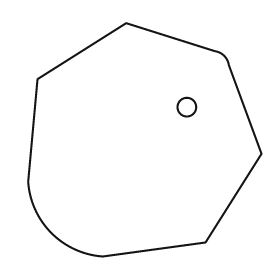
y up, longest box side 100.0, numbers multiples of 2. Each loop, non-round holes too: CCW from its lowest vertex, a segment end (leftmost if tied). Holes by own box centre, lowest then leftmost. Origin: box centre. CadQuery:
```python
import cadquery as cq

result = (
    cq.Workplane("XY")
    .moveTo(-18.0, -50.0)
    .lineTo(26.0, -44.0)
    .lineTo(50.0, -6.0)
    .lineTo(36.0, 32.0)
    .threePointArc((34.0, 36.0), (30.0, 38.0))
    .lineTo(-8.0, 50.0)
    .lineTo(-46.0, 26.0)
    .lineTo(-50.0, -18.0)
    .threePointArc((-40.0, -40.0), (-18.0, -50.0))
    .close()
    .moveTo(18.0, 14.0)
    .circle(4.0)
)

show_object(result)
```